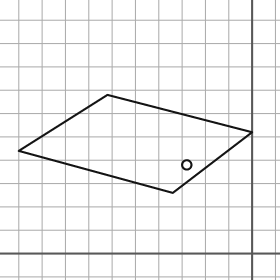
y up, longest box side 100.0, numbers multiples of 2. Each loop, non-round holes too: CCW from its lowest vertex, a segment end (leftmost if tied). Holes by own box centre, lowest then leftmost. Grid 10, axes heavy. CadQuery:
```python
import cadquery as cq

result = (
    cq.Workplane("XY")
    .moveTo(-34.0, 26.0)
    .lineTo(0.0, 52.0)
    .lineTo(-62.0, 68.0)
    .lineTo(-100.0, 44.0)
    .close()
    .moveTo(-28.0, 38.0)
    .circle(2.0)
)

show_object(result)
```